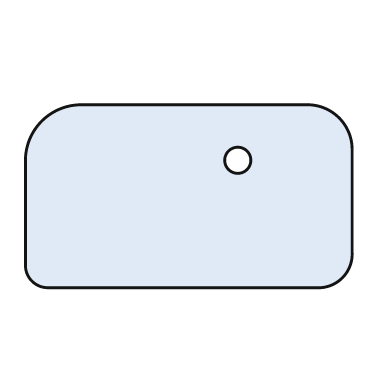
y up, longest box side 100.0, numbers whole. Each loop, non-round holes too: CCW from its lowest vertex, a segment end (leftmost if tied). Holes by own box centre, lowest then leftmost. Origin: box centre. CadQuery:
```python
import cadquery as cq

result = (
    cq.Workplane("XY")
    .moveTo(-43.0, -28.0)
    .lineTo(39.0, -28.0)
    .threePointArc((47.0, -25.0), (50.0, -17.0))
    .lineTo(50.0, 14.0)
    .threePointArc((46.0, 24.0), (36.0, 28.0))
    .lineTo(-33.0, 28.0)
    .threePointArc((-45.0, 23.0), (-50.0, 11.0))
    .lineTo(-50.0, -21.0)
    .threePointArc((-48.0, -26.0), (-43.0, -28.0))
    .close()
    .moveTo(15.0, 11.0)
    .circle(4.0)
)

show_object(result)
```